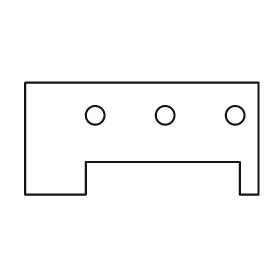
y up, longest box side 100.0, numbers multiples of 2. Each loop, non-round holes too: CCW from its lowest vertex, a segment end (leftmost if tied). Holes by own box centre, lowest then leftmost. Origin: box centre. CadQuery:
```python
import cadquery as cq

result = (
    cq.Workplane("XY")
    .moveTo(-50.0, -24.0)
    .lineTo(-24.0, -24.0)
    .lineTo(-24.0, -10.0)
    .lineTo(42.0, -10.0)
    .lineTo(42.0, -24.0)
    .lineTo(50.0, -24.0)
    .lineTo(50.0, 24.0)
    .lineTo(-50.0, 24.0)
    .close()
    .moveTo(-20.0, 10.0)
    .circle(4.0)
    .moveTo(10.0, 10.0)
    .circle(4.0)
    .moveTo(40.0, 10.0)
    .circle(4.0)
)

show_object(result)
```